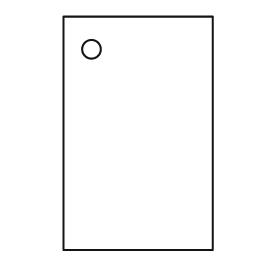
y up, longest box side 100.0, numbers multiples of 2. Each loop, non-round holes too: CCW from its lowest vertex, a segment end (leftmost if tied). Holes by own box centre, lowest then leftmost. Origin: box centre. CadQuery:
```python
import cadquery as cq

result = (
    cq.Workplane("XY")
    .moveTo(-32.0, -50.0)
    .lineTo(32.0, -50.0)
    .lineTo(32.0, 50.0)
    .lineTo(-32.0, 50.0)
    .close()
    .moveTo(-20.0, 36.0)
    .circle(4.0)
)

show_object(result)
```